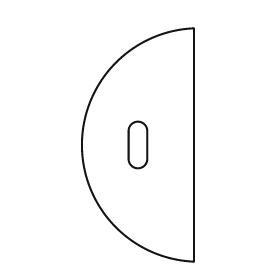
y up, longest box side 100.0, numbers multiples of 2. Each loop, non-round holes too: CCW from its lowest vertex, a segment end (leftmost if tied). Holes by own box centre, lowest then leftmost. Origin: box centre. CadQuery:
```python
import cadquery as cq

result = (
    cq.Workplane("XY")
    .moveTo(24.0, -50.0)
    .lineTo(24.0, 50.0)
    .threePointArc((-24.0, 0.0), (24.0, -50.0))
    .close()
    .moveTo(-4.0, -6.0)
    .threePointArc((0.0, -10.0), (4.0, -6.0))
    .lineTo(4.0, 6.0)
    .threePointArc((0.0, 10.0), (-4.0, 6.0))
    .close()
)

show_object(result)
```